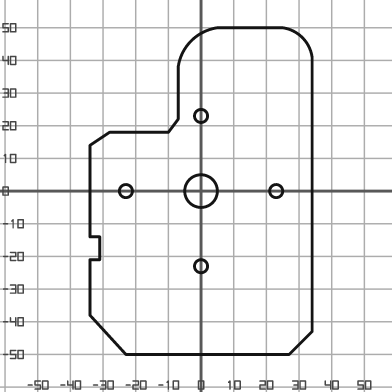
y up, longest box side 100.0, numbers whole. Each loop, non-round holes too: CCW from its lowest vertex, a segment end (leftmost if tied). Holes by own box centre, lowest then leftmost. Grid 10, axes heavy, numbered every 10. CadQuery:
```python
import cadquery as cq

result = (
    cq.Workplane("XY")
    .moveTo(-23.0, -50.0)
    .lineTo(27.0, -50.0)
    .lineTo(34.0, -43.0)
    .lineTo(34.0, 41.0)
    .threePointArc((31.0, 47.0), (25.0, 50.0))
    .lineTo(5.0, 50.0)
    .threePointArc((-3.0, 46.0), (-7.0, 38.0))
    .lineTo(-7.0, 22.0)
    .lineTo(-10.0, 18.0)
    .lineTo(-28.0, 18.0)
    .lineTo(-34.0, 14.0)
    .lineTo(-34.0, -14.0)
    .lineTo(-31.0, -14.0)
    .lineTo(-31.0, -21.0)
    .lineTo(-34.0, -21.0)
    .lineTo(-34.0, -38.0)
    .close()
    .moveTo(0.0, -23.0)
    .circle(2.0)
    .moveTo(-23.0, 0.0)
    .circle(2.0)
    .moveTo(0.0, 0.0)
    .circle(5.0)
    .moveTo(23.0, 0.0)
    .circle(2.0)
    .moveTo(0.0, 23.0)
    .circle(2.0)
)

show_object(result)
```